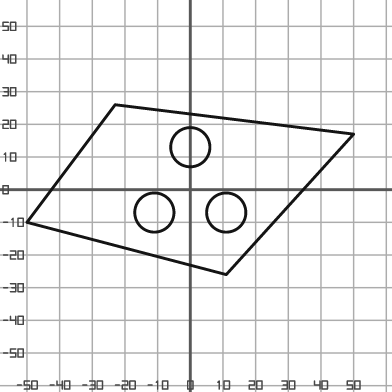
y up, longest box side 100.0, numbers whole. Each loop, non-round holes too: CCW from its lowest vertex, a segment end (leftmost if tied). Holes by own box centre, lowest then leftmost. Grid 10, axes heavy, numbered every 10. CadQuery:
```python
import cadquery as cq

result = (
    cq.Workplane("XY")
    .moveTo(11.0, -26.0)
    .lineTo(50.0, 17.0)
    .lineTo(-23.0, 26.0)
    .lineTo(-50.0, -10.0)
    .close()
    .moveTo(-11.0, -7.0)
    .circle(6.0)
    .moveTo(11.0, -7.0)
    .circle(6.0)
    .moveTo(0.0, 13.0)
    .circle(6.0)
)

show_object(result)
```